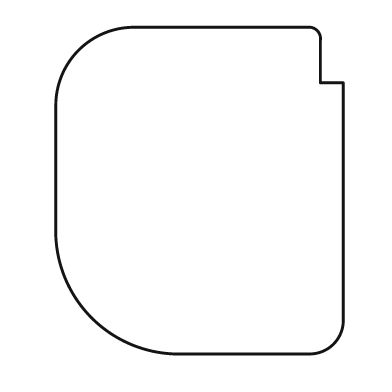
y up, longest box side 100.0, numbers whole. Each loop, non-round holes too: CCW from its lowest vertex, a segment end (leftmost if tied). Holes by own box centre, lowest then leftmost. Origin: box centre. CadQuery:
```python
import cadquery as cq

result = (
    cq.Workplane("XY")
    .moveTo(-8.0, -50.0)
    .lineTo(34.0, -50.0)
    .threePointArc((41.0, -47.0), (44.0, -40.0))
    .lineTo(44.0, 33.0)
    .lineTo(37.0, 33.0)
    .lineTo(37.0, 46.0)
    .threePointArc((36.0, 49.0), (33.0, 50.0))
    .lineTo(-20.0, 50.0)
    .threePointArc((-37.0, 43.0), (-44.0, 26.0))
    .lineTo(-44.0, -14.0)
    .threePointArc((-33.0, -39.0), (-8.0, -50.0))
    .close()
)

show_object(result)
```